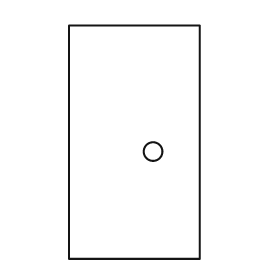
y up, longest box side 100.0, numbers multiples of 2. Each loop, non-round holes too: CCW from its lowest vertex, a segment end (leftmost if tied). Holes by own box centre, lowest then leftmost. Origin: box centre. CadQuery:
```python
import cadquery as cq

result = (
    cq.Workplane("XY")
    .moveTo(-28.0, -50.0)
    .lineTo(28.0, -50.0)
    .lineTo(28.0, 50.0)
    .lineTo(-28.0, 50.0)
    .close()
    .moveTo(8.0, -4.0)
    .circle(4.0)
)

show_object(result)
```